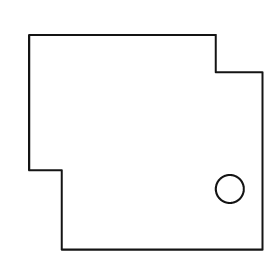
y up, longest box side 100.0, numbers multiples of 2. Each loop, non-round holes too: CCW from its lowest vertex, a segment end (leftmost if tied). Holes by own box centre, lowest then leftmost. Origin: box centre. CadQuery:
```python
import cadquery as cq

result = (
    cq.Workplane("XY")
    .moveTo(-36.0, -46.0)
    .lineTo(50.0, -46.0)
    .lineTo(50.0, 30.0)
    .lineTo(30.0, 30.0)
    .lineTo(30.0, 46.0)
    .lineTo(-50.0, 46.0)
    .lineTo(-50.0, -12.0)
    .lineTo(-36.0, -12.0)
    .close()
    .moveTo(36.0, -20.0)
    .circle(6.0)
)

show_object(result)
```